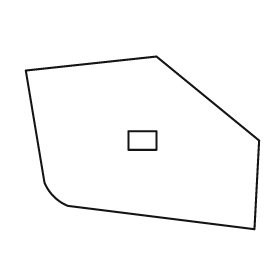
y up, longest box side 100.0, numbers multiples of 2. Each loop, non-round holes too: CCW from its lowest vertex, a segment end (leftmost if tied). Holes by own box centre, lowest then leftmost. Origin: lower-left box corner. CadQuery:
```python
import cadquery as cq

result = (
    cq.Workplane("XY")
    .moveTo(98.0, 0.0)
    .lineTo(100.0, 38.0)
    .lineTo(56.0, 74.0)
    .lineTo(0.0, 68.0)
    .lineTo(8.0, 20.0)
    .threePointArc((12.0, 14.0), (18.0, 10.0))
    .close()
    .moveTo(44.0, 34.0)
    .lineTo(56.0, 34.0)
    .lineTo(56.0, 42.0)
    .lineTo(44.0, 42.0)
    .close()
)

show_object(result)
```